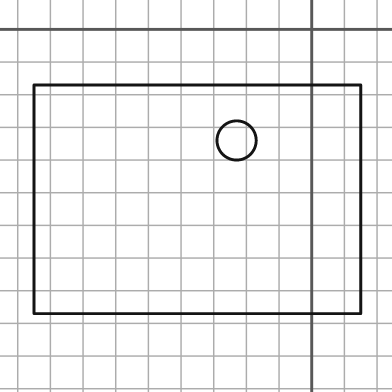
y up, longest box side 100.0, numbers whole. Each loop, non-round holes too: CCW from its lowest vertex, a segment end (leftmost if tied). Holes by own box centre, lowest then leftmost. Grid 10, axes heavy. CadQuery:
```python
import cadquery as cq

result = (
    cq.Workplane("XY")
    .moveTo(-85.0, -87.0)
    .lineTo(15.0, -87.0)
    .lineTo(15.0, -17.0)
    .lineTo(-85.0, -17.0)
    .close()
    .moveTo(-23.0, -34.0)
    .circle(6.0)
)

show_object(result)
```